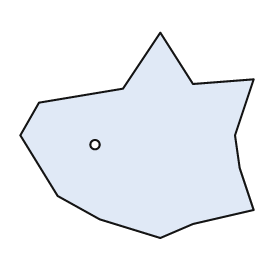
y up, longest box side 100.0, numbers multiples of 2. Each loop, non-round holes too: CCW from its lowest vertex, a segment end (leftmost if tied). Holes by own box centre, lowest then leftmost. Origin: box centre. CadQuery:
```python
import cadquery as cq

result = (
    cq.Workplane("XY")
    .moveTo(10.0, -44.0)
    .lineTo(24.0, -38.0)
    .lineTo(50.0, -32.0)
    .lineTo(44.0, -14.0)
    .lineTo(42.0, 0.0)
    .lineTo(50.0, 24.0)
    .lineTo(24.0, 22.0)
    .lineTo(10.0, 44.0)
    .lineTo(-6.0, 20.0)
    .lineTo(-42.0, 14.0)
    .lineTo(-50.0, 0.0)
    .lineTo(-34.0, -26.0)
    .lineTo(-16.0, -36.0)
    .close()
    .moveTo(-18.0, -4.0)
    .circle(2.0)
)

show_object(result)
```